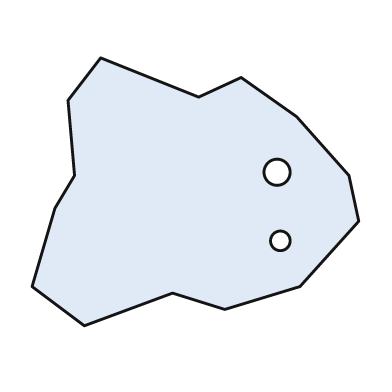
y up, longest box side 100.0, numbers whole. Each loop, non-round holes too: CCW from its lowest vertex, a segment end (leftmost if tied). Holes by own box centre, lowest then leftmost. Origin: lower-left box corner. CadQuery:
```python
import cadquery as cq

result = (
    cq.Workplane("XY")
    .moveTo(16.0, 0.0)
    .lineTo(43.0, 10.0)
    .lineTo(59.0, 5.0)
    .lineTo(82.0, 12.0)
    .lineTo(100.0, 32.0)
    .lineTo(97.0, 46.0)
    .lineTo(81.0, 64.0)
    .lineTo(64.0, 76.0)
    .lineTo(51.0, 70.0)
    .lineTo(21.0, 82.0)
    .lineTo(11.0, 69.0)
    .lineTo(13.0, 46.0)
    .lineTo(7.0, 36.0)
    .lineTo(0.0, 12.0)
    .close()
    .moveTo(76.0, 26.0)
    .circle(3.0)
    .moveTo(75.0, 47.0)
    .circle(4.0)
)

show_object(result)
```